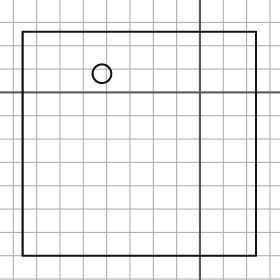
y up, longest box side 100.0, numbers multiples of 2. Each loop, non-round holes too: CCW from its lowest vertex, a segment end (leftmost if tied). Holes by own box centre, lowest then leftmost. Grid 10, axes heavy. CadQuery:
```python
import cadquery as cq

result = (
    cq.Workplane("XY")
    .moveTo(-76.0, -70.0)
    .lineTo(24.0, -70.0)
    .lineTo(24.0, 26.0)
    .lineTo(-76.0, 26.0)
    .close()
    .moveTo(-42.0, 8.0)
    .circle(4.0)
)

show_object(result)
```